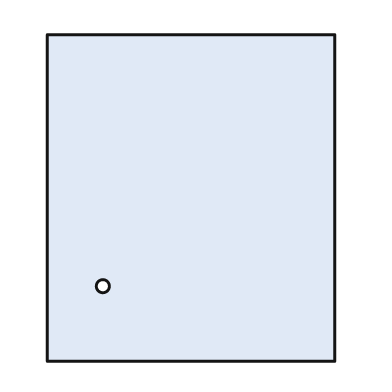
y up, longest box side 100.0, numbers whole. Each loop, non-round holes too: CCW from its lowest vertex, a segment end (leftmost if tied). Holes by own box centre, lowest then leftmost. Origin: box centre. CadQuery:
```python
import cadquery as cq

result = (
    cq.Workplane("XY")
    .moveTo(-44.0, -50.0)
    .lineTo(44.0, -50.0)
    .lineTo(44.0, 50.0)
    .lineTo(-44.0, 50.0)
    .close()
    .moveTo(-27.0, -27.0)
    .circle(2.0)
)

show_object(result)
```